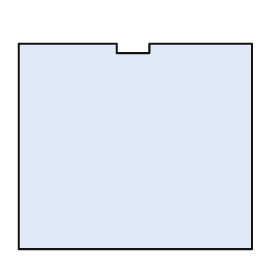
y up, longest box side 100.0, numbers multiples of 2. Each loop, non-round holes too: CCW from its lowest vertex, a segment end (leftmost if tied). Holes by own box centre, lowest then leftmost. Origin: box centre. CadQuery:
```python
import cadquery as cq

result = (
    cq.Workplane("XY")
    .moveTo(-50.0, -44.0)
    .lineTo(50.0, -44.0)
    .lineTo(50.0, 44.0)
    .lineTo(6.0, 44.0)
    .lineTo(6.0, 40.0)
    .lineTo(-8.0, 40.0)
    .lineTo(-8.0, 44.0)
    .lineTo(-50.0, 44.0)
    .close()
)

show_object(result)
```